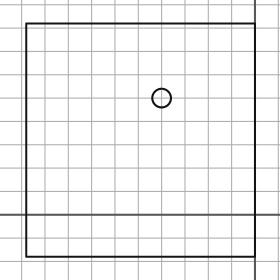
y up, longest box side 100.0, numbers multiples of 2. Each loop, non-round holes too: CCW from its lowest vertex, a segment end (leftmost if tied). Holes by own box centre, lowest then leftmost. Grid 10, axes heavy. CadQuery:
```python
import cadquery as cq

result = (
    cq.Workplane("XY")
    .moveTo(-98.0, -18.0)
    .lineTo(0.0, -18.0)
    .lineTo(0.0, 82.0)
    .lineTo(-98.0, 82.0)
    .close()
    .moveTo(-40.0, 50.0)
    .circle(4.0)
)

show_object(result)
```